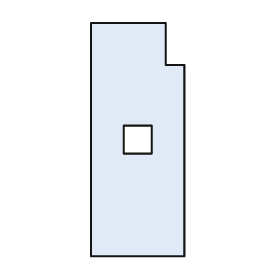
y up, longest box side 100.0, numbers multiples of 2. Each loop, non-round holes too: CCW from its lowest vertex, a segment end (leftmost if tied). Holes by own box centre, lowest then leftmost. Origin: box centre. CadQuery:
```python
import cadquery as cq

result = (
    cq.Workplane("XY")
    .moveTo(-20.0, -50.0)
    .lineTo(20.0, -50.0)
    .lineTo(20.0, 32.0)
    .lineTo(12.0, 32.0)
    .lineTo(12.0, 50.0)
    .lineTo(-20.0, 50.0)
    .close()
    .moveTo(-6.0, -6.0)
    .lineTo(6.0, -6.0)
    .lineTo(6.0, 6.0)
    .lineTo(-6.0, 6.0)
    .close()
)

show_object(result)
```